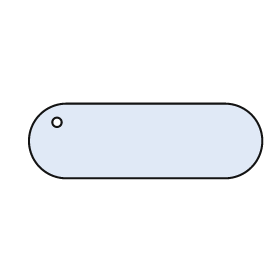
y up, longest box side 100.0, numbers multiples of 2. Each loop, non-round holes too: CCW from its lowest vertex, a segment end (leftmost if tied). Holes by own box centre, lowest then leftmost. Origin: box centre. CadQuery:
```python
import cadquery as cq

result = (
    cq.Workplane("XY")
    .moveTo(-34.0, -16.0)
    .lineTo(34.0, -16.0)
    .threePointArc((50.0, 0.0), (34.0, 16.0))
    .lineTo(-34.0, 16.0)
    .threePointArc((-50.0, 0.0), (-34.0, -16.0))
    .close()
    .moveTo(-38.0, 8.0)
    .circle(2.0)
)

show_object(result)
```